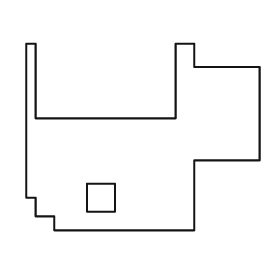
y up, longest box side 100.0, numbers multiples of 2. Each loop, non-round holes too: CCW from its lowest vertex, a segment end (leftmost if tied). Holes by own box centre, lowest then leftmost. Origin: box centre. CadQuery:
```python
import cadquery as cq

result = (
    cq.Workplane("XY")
    .moveTo(-38.0, -40.0)
    .lineTo(22.0, -40.0)
    .lineTo(22.0, -10.0)
    .lineTo(50.0, -10.0)
    .lineTo(50.0, 30.0)
    .lineTo(22.0, 30.0)
    .lineTo(22.0, 40.0)
    .lineTo(14.0, 40.0)
    .lineTo(14.0, 8.0)
    .lineTo(-46.0, 8.0)
    .lineTo(-46.0, 40.0)
    .lineTo(-50.0, 40.0)
    .lineTo(-50.0, -26.0)
    .lineTo(-46.0, -26.0)
    .lineTo(-46.0, -34.0)
    .lineTo(-38.0, -34.0)
    .close()
    .moveTo(-24.0, -32.0)
    .lineTo(-12.0, -32.0)
    .lineTo(-12.0, -20.0)
    .lineTo(-24.0, -20.0)
    .close()
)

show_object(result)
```